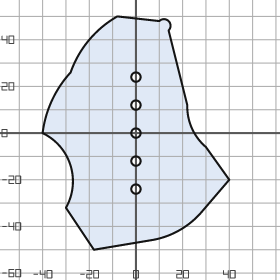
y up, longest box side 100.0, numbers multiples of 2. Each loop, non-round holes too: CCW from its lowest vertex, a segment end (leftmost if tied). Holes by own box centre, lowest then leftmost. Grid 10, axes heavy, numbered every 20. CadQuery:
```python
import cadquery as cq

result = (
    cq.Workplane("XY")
    .moveTo(-18.0, -50.0)
    .lineTo(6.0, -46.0)
    .threePointArc((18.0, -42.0), (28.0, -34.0))
    .lineTo(40.0, -20.0)
    .lineTo(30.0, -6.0)
    .threePointArc((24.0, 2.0), (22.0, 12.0))
    .lineTo(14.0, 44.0)
    .threePointArc((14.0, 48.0), (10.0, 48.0))
    .lineTo(-8.0, 50.0)
    .threePointArc((-20.0, 40.0), (-28.0, 26.0))
    .threePointArc((-36.0, 14.0), (-40.0, 0.0))
    .threePointArc((-28.0, -14.0), (-30.0, -32.0))
    .close()
    .moveTo(0.0, -24.0)
    .circle(2.0)
    .moveTo(0.0, -12.0)
    .circle(2.0)
    .moveTo(0.0, 0.0)
    .circle(2.0)
    .moveTo(0.0, 12.0)
    .circle(2.0)
    .moveTo(0.0, 24.0)
    .circle(2.0)
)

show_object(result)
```